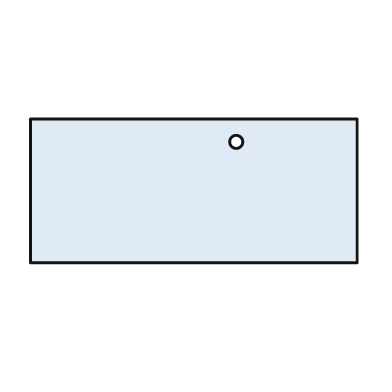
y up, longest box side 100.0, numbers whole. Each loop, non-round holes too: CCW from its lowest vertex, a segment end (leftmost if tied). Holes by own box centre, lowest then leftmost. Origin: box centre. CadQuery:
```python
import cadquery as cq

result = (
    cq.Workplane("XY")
    .moveTo(-50.0, -22.0)
    .lineTo(50.0, -22.0)
    .lineTo(50.0, 22.0)
    .lineTo(-50.0, 22.0)
    .close()
    .moveTo(13.0, 15.0)
    .circle(2.0)
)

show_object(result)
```